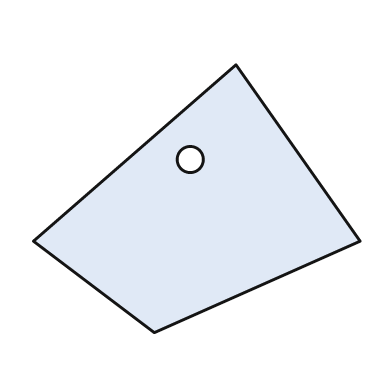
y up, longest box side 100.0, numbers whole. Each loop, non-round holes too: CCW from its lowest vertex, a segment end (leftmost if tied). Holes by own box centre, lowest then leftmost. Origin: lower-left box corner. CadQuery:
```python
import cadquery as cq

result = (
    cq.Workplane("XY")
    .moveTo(37.0, 0.0)
    .lineTo(100.0, 28.0)
    .lineTo(62.0, 82.0)
    .lineTo(0.0, 28.0)
    .close()
    .moveTo(48.0, 53.0)
    .circle(4.0)
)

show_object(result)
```